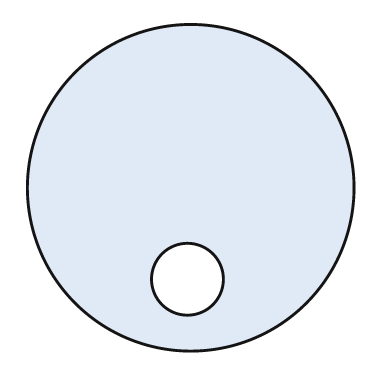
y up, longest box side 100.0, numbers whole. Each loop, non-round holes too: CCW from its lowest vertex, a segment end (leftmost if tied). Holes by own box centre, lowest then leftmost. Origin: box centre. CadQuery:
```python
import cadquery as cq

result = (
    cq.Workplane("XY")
    .moveTo(0.0, 0.0)
    .circle(50.0)
    .moveTo(-1.0, -28.0)
    .circle(11.0)
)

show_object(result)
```